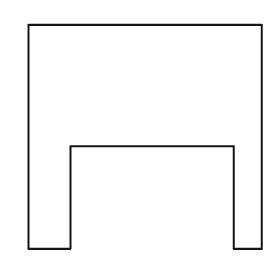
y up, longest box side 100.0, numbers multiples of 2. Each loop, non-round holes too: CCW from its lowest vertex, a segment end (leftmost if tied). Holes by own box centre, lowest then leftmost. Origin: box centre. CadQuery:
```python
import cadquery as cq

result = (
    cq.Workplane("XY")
    .moveTo(-50.0, -48.0)
    .lineTo(-32.0, -48.0)
    .lineTo(-32.0, -4.0)
    .lineTo(38.0, -4.0)
    .lineTo(38.0, -48.0)
    .lineTo(50.0, -48.0)
    .lineTo(50.0, 48.0)
    .lineTo(-50.0, 48.0)
    .close()
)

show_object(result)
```